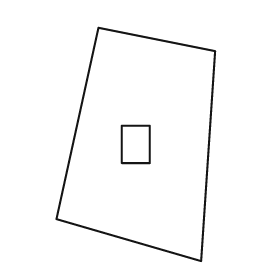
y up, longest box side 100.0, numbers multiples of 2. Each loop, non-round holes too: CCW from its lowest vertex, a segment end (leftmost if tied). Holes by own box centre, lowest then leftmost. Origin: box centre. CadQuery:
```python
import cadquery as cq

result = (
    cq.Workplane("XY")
    .moveTo(28.0, -50.0)
    .lineTo(34.0, 40.0)
    .lineTo(-16.0, 50.0)
    .lineTo(-34.0, -32.0)
    .close()
    .moveTo(-6.0, -8.0)
    .lineTo(6.0, -8.0)
    .lineTo(6.0, 8.0)
    .lineTo(-6.0, 8.0)
    .close()
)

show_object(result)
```